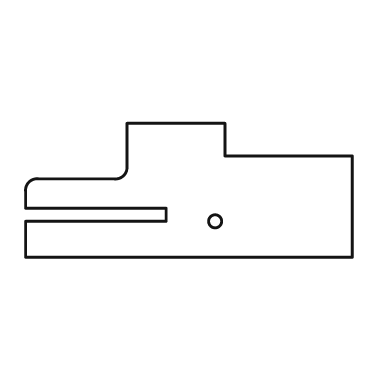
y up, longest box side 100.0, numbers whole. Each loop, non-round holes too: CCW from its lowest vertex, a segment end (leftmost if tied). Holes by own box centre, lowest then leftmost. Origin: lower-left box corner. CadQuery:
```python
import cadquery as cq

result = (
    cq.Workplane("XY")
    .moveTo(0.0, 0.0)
    .lineTo(100.0, 0.0)
    .lineTo(100.0, 31.0)
    .lineTo(61.0, 31.0)
    .lineTo(61.0, 41.0)
    .lineTo(31.0, 41.0)
    .lineTo(31.0, 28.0)
    .threePointArc((30.0, 25.0), (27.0, 24.0))
    .lineTo(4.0, 24.0)
    .threePointArc((1.0, 23.0), (0.0, 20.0))
    .lineTo(0.0, 15.0)
    .lineTo(43.0, 15.0)
    .lineTo(43.0, 11.0)
    .lineTo(0.0, 11.0)
    .close()
    .moveTo(58.0, 11.0)
    .circle(2.0)
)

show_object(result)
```